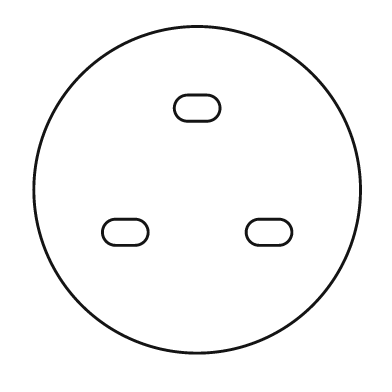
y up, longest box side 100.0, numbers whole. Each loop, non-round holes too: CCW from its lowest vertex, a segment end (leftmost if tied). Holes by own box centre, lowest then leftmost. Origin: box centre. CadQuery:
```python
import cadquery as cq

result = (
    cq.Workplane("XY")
    .moveTo(0.0, 0.0)
    .circle(50.0)
    .moveTo(-25.0, -17.0)
    .lineTo(-19.0, -17.0)
    .threePointArc((-15.0, -13.0), (-19.0, -9.0))
    .lineTo(-25.0, -9.0)
    .threePointArc((-29.0, -13.0), (-25.0, -17.0))
    .close()
    .moveTo(19.0, -17.0)
    .lineTo(25.0, -17.0)
    .threePointArc((29.0, -13.0), (25.0, -9.0))
    .lineTo(19.0, -9.0)
    .threePointArc((15.0, -13.0), (19.0, -17.0))
    .close()
    .moveTo(-3.0, 21.0)
    .lineTo(3.0, 21.0)
    .threePointArc((7.0, 25.0), (3.0, 29.0))
    .lineTo(-3.0, 29.0)
    .threePointArc((-7.0, 25.0), (-3.0, 21.0))
    .close()
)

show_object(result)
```